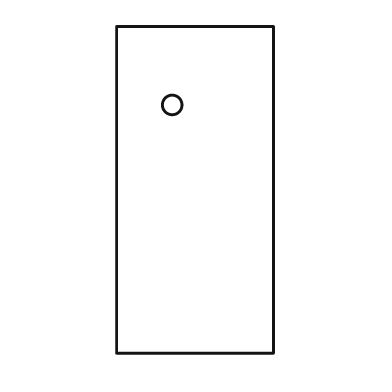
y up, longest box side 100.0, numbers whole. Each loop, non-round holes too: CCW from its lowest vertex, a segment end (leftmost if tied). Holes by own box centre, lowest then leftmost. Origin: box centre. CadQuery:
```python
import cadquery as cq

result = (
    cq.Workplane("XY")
    .moveTo(-24.0, -50.0)
    .lineTo(24.0, -50.0)
    .lineTo(24.0, 50.0)
    .lineTo(-24.0, 50.0)
    .close()
    .moveTo(-7.0, 26.0)
    .circle(3.0)
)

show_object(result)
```